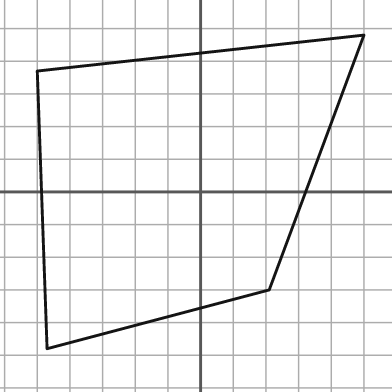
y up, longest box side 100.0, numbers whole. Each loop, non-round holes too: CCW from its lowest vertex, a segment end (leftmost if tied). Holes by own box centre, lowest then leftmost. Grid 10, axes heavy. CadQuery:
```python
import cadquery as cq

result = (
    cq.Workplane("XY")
    .moveTo(-47.0, -48.0)
    .lineTo(21.0, -30.0)
    .lineTo(50.0, 48.0)
    .lineTo(-50.0, 37.0)
    .close()
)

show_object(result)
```